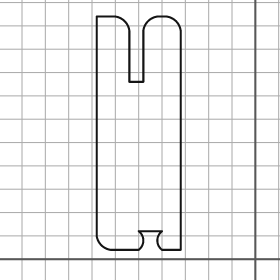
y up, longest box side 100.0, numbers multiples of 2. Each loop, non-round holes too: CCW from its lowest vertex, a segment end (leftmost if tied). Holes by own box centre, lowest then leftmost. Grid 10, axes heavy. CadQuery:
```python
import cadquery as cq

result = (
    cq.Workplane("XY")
    .moveTo(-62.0, 4.0)
    .lineTo(-50.0, 4.0)
    .threePointArc((-48.0, 8.0), (-50.0, 12.0))
    .lineTo(-40.0, 12.0)
    .threePointArc((-42.0, 8.0), (-40.0, 4.0))
    .lineTo(-32.0, 4.0)
    .lineTo(-32.0, 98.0)
    .threePointArc((-34.0, 102.0), (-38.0, 104.0))
    .lineTo(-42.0, 104.0)
    .threePointArc((-46.0, 102.0), (-48.0, 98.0))
    .lineTo(-48.0, 76.0)
    .lineTo(-54.0, 76.0)
    .lineTo(-54.0, 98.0)
    .threePointArc((-56.0, 102.0), (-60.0, 104.0))
    .lineTo(-68.0, 104.0)
    .lineTo(-68.0, 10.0)
    .threePointArc((-66.0, 6.0), (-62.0, 4.0))
    .close()
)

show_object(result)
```